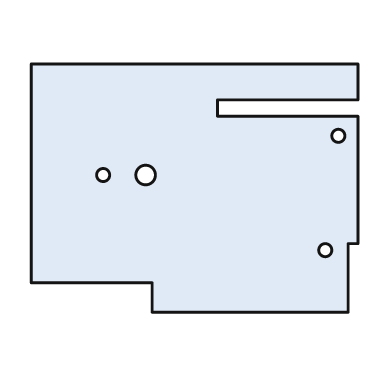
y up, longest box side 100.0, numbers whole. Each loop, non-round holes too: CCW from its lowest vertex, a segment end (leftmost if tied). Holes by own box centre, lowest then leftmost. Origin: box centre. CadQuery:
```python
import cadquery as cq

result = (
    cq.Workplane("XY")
    .moveTo(-13.0, -38.0)
    .lineTo(47.0, -38.0)
    .lineTo(47.0, -17.0)
    .lineTo(50.0, -17.0)
    .lineTo(50.0, 22.0)
    .lineTo(7.0, 22.0)
    .lineTo(7.0, 27.0)
    .lineTo(50.0, 27.0)
    .lineTo(50.0, 38.0)
    .lineTo(-50.0, 38.0)
    .lineTo(-50.0, -29.0)
    .lineTo(-13.0, -29.0)
    .close()
    .moveTo(40.0, -19.0)
    .circle(2.0)
    .moveTo(-28.0, 4.0)
    .circle(2.0)
    .moveTo(-15.0, 4.0)
    .circle(3.0)
    .moveTo(44.0, 16.0)
    .circle(2.0)
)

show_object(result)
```